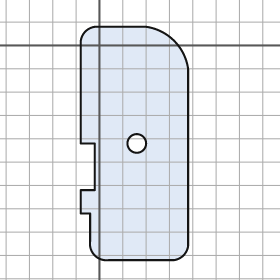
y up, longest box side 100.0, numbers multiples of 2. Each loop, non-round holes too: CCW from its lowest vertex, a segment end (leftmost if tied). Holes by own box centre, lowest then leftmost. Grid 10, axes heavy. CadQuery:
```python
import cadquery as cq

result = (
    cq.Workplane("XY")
    .moveTo(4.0, -92.0)
    .lineTo(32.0, -92.0)
    .threePointArc((36.0, -90.0), (38.0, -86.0))
    .lineTo(38.0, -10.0)
    .threePointArc((32.0, 2.0), (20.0, 8.0))
    .lineTo(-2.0, 8.0)
    .threePointArc((-6.0, 6.0), (-8.0, 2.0))
    .lineTo(-8.0, -42.0)
    .lineTo(-2.0, -42.0)
    .lineTo(-2.0, -62.0)
    .lineTo(-8.0, -62.0)
    .lineTo(-8.0, -72.0)
    .lineTo(-4.0, -72.0)
    .lineTo(-4.0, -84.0)
    .threePointArc((-2.0, -90.0), (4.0, -92.0))
    .close()
    .moveTo(16.0, -42.0)
    .circle(4.0)
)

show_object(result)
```